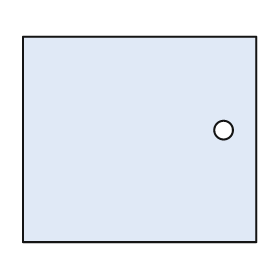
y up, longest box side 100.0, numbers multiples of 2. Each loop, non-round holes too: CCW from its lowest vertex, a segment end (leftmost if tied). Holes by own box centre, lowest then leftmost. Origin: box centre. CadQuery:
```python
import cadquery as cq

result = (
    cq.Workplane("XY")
    .moveTo(-50.0, -44.0)
    .lineTo(50.0, -44.0)
    .lineTo(50.0, 44.0)
    .lineTo(-50.0, 44.0)
    .close()
    .moveTo(36.0, 4.0)
    .circle(4.0)
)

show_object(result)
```